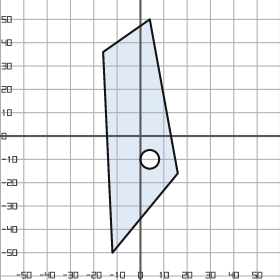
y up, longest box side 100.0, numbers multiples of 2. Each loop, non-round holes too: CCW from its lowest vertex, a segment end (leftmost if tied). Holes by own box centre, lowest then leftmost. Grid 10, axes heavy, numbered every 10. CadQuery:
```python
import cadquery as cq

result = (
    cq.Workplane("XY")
    .moveTo(-12.0, -50.0)
    .lineTo(16.0, -16.0)
    .lineTo(4.0, 50.0)
    .lineTo(-16.0, 36.0)
    .close()
    .moveTo(4.0, -10.0)
    .circle(4.0)
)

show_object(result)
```